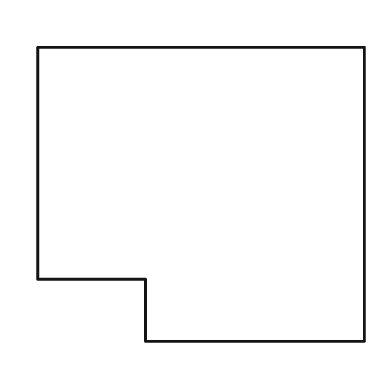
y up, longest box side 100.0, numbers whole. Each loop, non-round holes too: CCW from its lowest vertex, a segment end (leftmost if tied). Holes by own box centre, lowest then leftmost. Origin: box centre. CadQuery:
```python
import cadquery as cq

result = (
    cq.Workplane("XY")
    .moveTo(-17.0, -45.0)
    .lineTo(50.0, -45.0)
    .lineTo(50.0, 45.0)
    .lineTo(-50.0, 45.0)
    .lineTo(-50.0, -26.0)
    .lineTo(-17.0, -26.0)
    .close()
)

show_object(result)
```